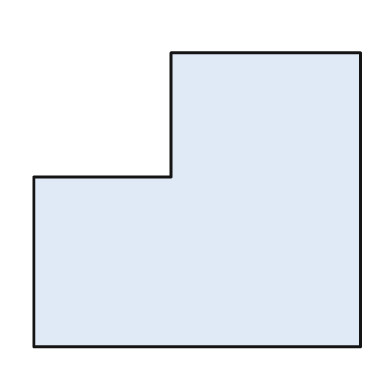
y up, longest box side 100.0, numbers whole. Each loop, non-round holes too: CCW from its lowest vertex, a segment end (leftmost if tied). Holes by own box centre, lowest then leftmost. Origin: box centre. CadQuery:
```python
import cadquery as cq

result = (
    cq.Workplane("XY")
    .moveTo(-50.0, -45.0)
    .lineTo(50.0, -45.0)
    .lineTo(50.0, 45.0)
    .lineTo(-8.0, 45.0)
    .lineTo(-8.0, 7.0)
    .lineTo(-50.0, 7.0)
    .close()
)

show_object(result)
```